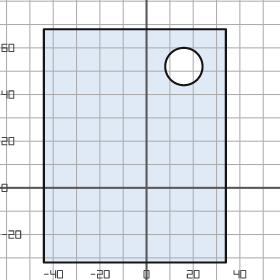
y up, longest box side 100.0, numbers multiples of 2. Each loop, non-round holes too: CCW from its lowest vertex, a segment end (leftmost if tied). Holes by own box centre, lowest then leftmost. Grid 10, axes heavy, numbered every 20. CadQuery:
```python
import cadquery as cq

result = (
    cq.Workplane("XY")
    .moveTo(-44.0, -32.0)
    .lineTo(34.0, -32.0)
    .lineTo(34.0, 68.0)
    .lineTo(-44.0, 68.0)
    .close()
    .moveTo(16.0, 52.0)
    .circle(8.0)
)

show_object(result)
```